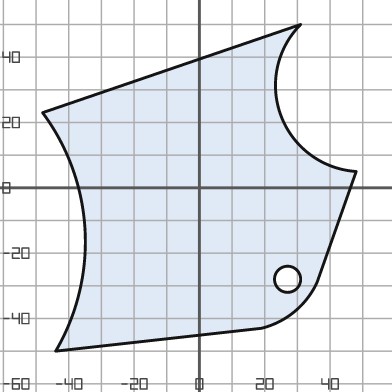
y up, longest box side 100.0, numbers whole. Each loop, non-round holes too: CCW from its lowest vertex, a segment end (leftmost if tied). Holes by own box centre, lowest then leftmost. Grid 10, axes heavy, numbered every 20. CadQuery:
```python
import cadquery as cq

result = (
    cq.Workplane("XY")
    .moveTo(-44.0, -50.0)
    .lineTo(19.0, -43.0)
    .threePointArc((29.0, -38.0), (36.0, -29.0))
    .lineTo(48.0, 5.0)
    .threePointArc((25.0, 22.0), (31.0, 50.0))
    .lineTo(-48.0, 23.0)
    .threePointArc((-35.0, -13.0), (-44.0, -50.0))
    .close()
    .moveTo(27.0, -28.0)
    .circle(4.0)
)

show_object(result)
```